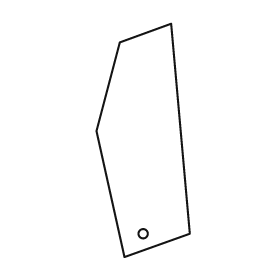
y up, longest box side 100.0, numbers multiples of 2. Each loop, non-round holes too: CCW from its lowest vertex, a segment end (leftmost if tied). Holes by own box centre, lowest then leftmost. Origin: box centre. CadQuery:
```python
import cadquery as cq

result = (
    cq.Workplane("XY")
    .moveTo(-8.0, -50.0)
    .lineTo(20.0, -40.0)
    .lineTo(12.0, 50.0)
    .lineTo(-10.0, 42.0)
    .lineTo(-20.0, 4.0)
    .close()
    .moveTo(0.0, -40.0)
    .circle(2.0)
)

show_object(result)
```